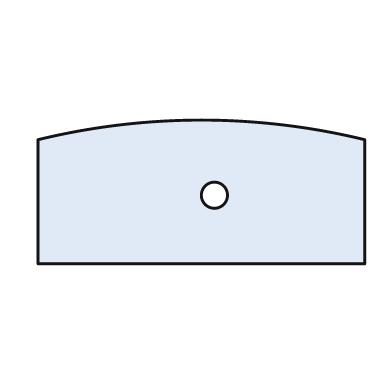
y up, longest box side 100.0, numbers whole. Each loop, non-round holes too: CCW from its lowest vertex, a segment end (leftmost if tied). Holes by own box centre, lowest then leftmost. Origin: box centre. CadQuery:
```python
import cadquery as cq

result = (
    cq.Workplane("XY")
    .moveTo(-50.0, -22.0)
    .lineTo(50.0, -22.0)
    .lineTo(50.0, 16.0)
    .threePointArc((0.0, 22.0), (-50.0, 16.0))
    .close()
    .moveTo(4.0, -1.0)
    .circle(4.0)
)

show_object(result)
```